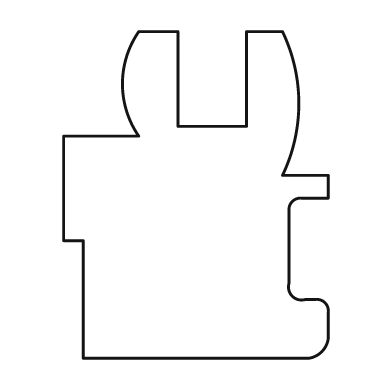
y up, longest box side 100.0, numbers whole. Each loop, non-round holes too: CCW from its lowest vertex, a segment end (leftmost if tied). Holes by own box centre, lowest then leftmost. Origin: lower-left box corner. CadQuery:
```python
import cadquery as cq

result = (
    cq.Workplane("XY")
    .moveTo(6.0, 0.0)
    .lineTo(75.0, 0.0)
    .threePointArc((79.0, 2.0), (81.0, 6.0))
    .lineTo(81.0, 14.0)
    .threePointArc((80.0, 17.0), (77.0, 18.0))
    .lineTo(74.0, 18.0)
    .threePointArc((70.0, 19.0), (69.0, 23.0))
    .lineTo(69.0, 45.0)
    .threePointArc((70.0, 48.0), (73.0, 49.0))
    .lineTo(81.0, 49.0)
    .lineTo(81.0, 56.0)
    .lineTo(67.0, 56.0)
    .threePointArc((72.0, 78.0), (67.0, 100.0))
    .lineTo(56.0, 100.0)
    .lineTo(56.0, 71.0)
    .lineTo(35.0, 71.0)
    .lineTo(35.0, 100.0)
    .lineTo(23.0, 100.0)
    .threePointArc((18.0, 84.0), (23.0, 68.0))
    .lineTo(0.0, 68.0)
    .lineTo(0.0, 36.0)
    .lineTo(6.0, 36.0)
    .close()
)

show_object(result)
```